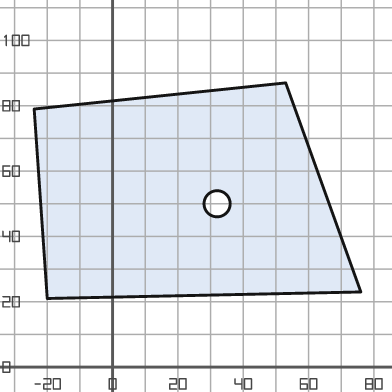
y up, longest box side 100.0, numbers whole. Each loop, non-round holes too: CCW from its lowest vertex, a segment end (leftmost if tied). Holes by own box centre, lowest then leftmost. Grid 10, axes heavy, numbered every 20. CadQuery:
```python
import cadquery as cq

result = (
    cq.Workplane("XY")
    .moveTo(-20.0, 21.0)
    .lineTo(76.0, 23.0)
    .lineTo(53.0, 87.0)
    .lineTo(-24.0, 79.0)
    .close()
    .moveTo(32.0, 50.0)
    .circle(4.0)
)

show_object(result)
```